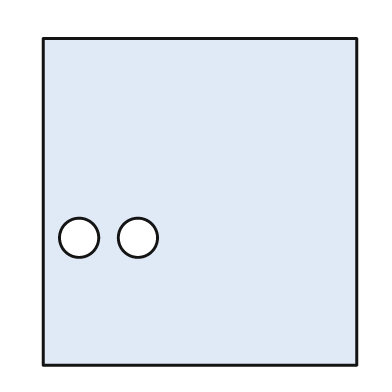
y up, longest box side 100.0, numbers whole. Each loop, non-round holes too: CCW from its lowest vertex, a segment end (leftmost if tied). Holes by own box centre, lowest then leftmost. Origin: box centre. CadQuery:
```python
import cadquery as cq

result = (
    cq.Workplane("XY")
    .moveTo(-48.0, -50.0)
    .lineTo(48.0, -50.0)
    .lineTo(48.0, 50.0)
    .lineTo(-48.0, 50.0)
    .close()
    .moveTo(-37.0, -11.0)
    .circle(6.0)
    .moveTo(-19.0, -11.0)
    .circle(6.0)
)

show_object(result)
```